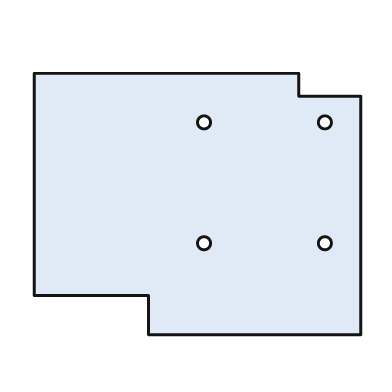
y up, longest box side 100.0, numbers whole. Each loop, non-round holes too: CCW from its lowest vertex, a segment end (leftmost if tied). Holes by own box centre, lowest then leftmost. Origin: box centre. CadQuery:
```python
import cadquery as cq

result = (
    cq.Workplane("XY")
    .moveTo(-15.0, -40.0)
    .lineTo(50.0, -40.0)
    .lineTo(50.0, 33.0)
    .lineTo(31.0, 33.0)
    .lineTo(31.0, 40.0)
    .lineTo(-50.0, 40.0)
    .lineTo(-50.0, -28.0)
    .lineTo(-15.0, -28.0)
    .close()
    .moveTo(2.0, -12.0)
    .circle(2.0)
    .moveTo(39.0, -12.0)
    .circle(2.0)
    .moveTo(2.0, 25.0)
    .circle(2.0)
    .moveTo(39.0, 25.0)
    .circle(2.0)
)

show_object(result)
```